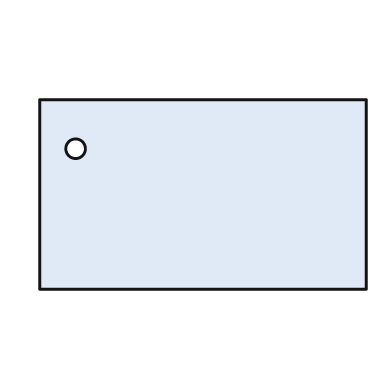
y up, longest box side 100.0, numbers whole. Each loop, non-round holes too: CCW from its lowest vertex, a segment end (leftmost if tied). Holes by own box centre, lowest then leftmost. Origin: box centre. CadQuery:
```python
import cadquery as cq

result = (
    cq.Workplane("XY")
    .moveTo(-50.0, -29.0)
    .lineTo(50.0, -29.0)
    .lineTo(50.0, 29.0)
    .lineTo(-50.0, 29.0)
    .close()
    .moveTo(-39.0, 14.0)
    .circle(3.0)
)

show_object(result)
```